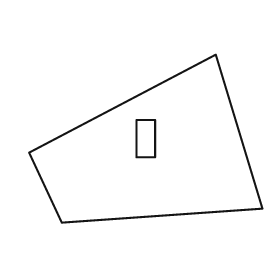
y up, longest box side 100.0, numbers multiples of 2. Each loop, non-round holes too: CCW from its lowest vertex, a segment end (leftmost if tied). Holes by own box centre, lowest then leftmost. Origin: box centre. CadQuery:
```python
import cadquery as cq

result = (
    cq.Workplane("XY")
    .moveTo(-36.0, -36.0)
    .lineTo(50.0, -30.0)
    .lineTo(30.0, 36.0)
    .lineTo(-50.0, -6.0)
    .close()
    .moveTo(-4.0, -8.0)
    .lineTo(4.0, -8.0)
    .lineTo(4.0, 8.0)
    .lineTo(-4.0, 8.0)
    .close()
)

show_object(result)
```